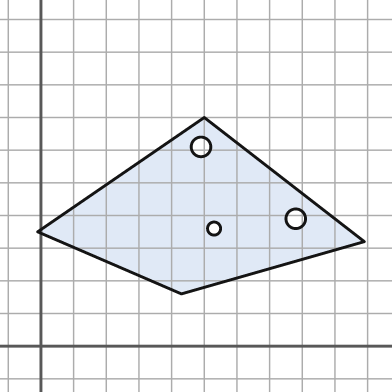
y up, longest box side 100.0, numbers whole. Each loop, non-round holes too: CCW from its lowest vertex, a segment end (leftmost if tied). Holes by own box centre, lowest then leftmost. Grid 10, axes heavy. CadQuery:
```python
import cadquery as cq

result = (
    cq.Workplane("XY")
    .moveTo(43.0, 16.0)
    .lineTo(99.0, 32.0)
    .lineTo(50.0, 70.0)
    .lineTo(-1.0, 35.0)
    .close()
    .moveTo(53.0, 36.0)
    .circle(2.0)
    .moveTo(78.0, 39.0)
    .circle(3.0)
    .moveTo(49.0, 61.0)
    .circle(3.0)
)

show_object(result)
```